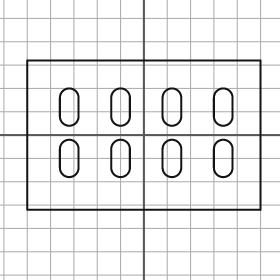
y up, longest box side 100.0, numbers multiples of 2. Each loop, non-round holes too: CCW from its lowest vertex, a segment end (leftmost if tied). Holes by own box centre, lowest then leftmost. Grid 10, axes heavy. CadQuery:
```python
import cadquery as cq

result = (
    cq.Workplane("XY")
    .moveTo(-50.0, -32.0)
    .lineTo(50.0, -32.0)
    .lineTo(50.0, 32.0)
    .lineTo(-50.0, 32.0)
    .close()
    .moveTo(-36.0, -14.0)
    .threePointArc((-32.0, -18.0), (-28.0, -14.0))
    .lineTo(-28.0, -6.0)
    .threePointArc((-32.0, -2.0), (-36.0, -6.0))
    .close()
    .moveTo(-14.0, -14.0)
    .threePointArc((-10.0, -18.0), (-6.0, -14.0))
    .lineTo(-6.0, -6.0)
    .threePointArc((-10.0, -2.0), (-14.0, -6.0))
    .close()
    .moveTo(8.0, -14.0)
    .threePointArc((12.0, -18.0), (16.0, -14.0))
    .lineTo(16.0, -6.0)
    .threePointArc((12.0, -2.0), (8.0, -6.0))
    .close()
    .moveTo(30.0, -14.0)
    .threePointArc((34.0, -18.0), (38.0, -14.0))
    .lineTo(38.0, -6.0)
    .threePointArc((34.0, -2.0), (30.0, -6.0))
    .close()
    .moveTo(-36.0, 8.0)
    .threePointArc((-32.0, 4.0), (-28.0, 8.0))
    .lineTo(-28.0, 16.0)
    .threePointArc((-32.0, 20.0), (-36.0, 16.0))
    .close()
    .moveTo(-14.0, 8.0)
    .threePointArc((-10.0, 4.0), (-6.0, 8.0))
    .lineTo(-6.0, 16.0)
    .threePointArc((-10.0, 20.0), (-14.0, 16.0))
    .close()
    .moveTo(8.0, 8.0)
    .threePointArc((12.0, 4.0), (16.0, 8.0))
    .lineTo(16.0, 16.0)
    .threePointArc((12.0, 20.0), (8.0, 16.0))
    .close()
    .moveTo(30.0, 8.0)
    .threePointArc((34.0, 4.0), (38.0, 8.0))
    .lineTo(38.0, 16.0)
    .threePointArc((34.0, 20.0), (30.0, 16.0))
    .close()
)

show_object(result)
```